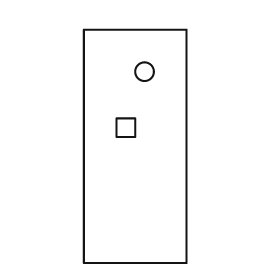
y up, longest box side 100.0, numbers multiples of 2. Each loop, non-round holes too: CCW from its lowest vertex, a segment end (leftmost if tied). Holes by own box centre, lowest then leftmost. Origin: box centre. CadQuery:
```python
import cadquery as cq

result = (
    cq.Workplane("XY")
    .moveTo(-22.0, -50.0)
    .lineTo(22.0, -50.0)
    .lineTo(22.0, 50.0)
    .lineTo(-22.0, 50.0)
    .close()
    .moveTo(-8.0, 4.0)
    .lineTo(0.0, 4.0)
    .lineTo(0.0, 12.0)
    .lineTo(-8.0, 12.0)
    .close()
    .moveTo(4.0, 32.0)
    .circle(4.0)
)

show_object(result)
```